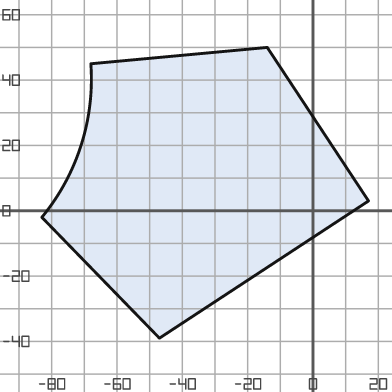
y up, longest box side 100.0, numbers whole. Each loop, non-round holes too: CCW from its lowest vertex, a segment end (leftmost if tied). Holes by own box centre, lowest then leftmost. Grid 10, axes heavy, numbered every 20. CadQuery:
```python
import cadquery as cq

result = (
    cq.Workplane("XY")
    .moveTo(-47.0, -39.0)
    .lineTo(17.0, 3.0)
    .lineTo(-14.0, 50.0)
    .lineTo(-68.0, 45.0)
    .threePointArc((-71.0, 20.0), (-83.0, -2.0))
    .close()
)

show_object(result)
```